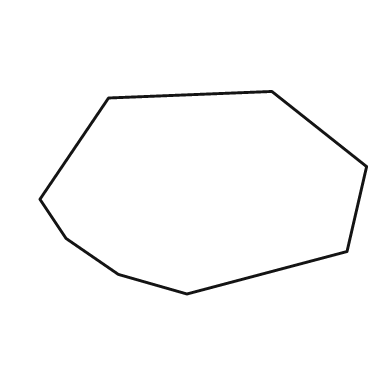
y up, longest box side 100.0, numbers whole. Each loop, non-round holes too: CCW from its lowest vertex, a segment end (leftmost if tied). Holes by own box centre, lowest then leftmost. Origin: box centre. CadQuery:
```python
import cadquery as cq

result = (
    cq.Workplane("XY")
    .moveTo(-5.0, -31.0)
    .lineTo(44.0, -18.0)
    .lineTo(50.0, 8.0)
    .lineTo(21.0, 31.0)
    .lineTo(-29.0, 29.0)
    .lineTo(-50.0, -2.0)
    .lineTo(-42.0, -14.0)
    .lineTo(-26.0, -25.0)
    .close()
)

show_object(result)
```